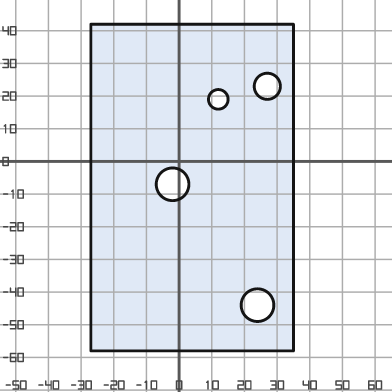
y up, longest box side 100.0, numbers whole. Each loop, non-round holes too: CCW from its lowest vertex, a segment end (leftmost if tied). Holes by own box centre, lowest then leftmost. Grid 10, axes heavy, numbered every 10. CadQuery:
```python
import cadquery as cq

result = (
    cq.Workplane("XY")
    .moveTo(-27.0, -58.0)
    .lineTo(35.0, -58.0)
    .lineTo(35.0, 42.0)
    .lineTo(-27.0, 42.0)
    .close()
    .moveTo(24.0, -44.0)
    .circle(5.0)
    .moveTo(-2.0, -7.0)
    .circle(5.0)
    .moveTo(12.0, 19.0)
    .circle(3.0)
    .moveTo(27.0, 23.0)
    .circle(4.0)
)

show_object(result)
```